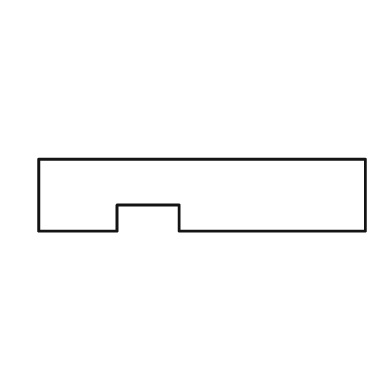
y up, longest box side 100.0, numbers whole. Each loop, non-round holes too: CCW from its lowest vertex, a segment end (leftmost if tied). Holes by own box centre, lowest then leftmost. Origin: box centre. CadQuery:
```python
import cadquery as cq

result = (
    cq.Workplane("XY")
    .moveTo(-50.0, -11.0)
    .lineTo(-26.0, -11.0)
    .lineTo(-26.0, -3.0)
    .lineTo(-7.0, -3.0)
    .lineTo(-7.0, -11.0)
    .lineTo(50.0, -11.0)
    .lineTo(50.0, 11.0)
    .lineTo(-50.0, 11.0)
    .close()
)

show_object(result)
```